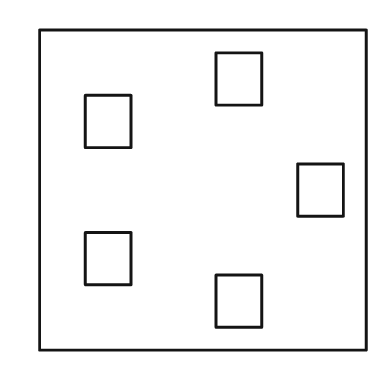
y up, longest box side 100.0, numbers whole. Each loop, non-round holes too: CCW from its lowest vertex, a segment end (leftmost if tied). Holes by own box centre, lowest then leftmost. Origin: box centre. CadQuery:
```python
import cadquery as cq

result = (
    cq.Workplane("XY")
    .moveTo(-50.0, -49.0)
    .lineTo(50.0, -49.0)
    .lineTo(50.0, 49.0)
    .lineTo(-50.0, 49.0)
    .close()
    .moveTo(4.0, -42.0)
    .lineTo(18.0, -42.0)
    .lineTo(18.0, -26.0)
    .lineTo(4.0, -26.0)
    .close()
    .moveTo(-36.0, -29.0)
    .lineTo(-22.0, -29.0)
    .lineTo(-22.0, -13.0)
    .lineTo(-36.0, -13.0)
    .close()
    .moveTo(29.0, -8.0)
    .lineTo(43.0, -8.0)
    .lineTo(43.0, 8.0)
    .lineTo(29.0, 8.0)
    .close()
    .moveTo(-36.0, 13.0)
    .lineTo(-22.0, 13.0)
    .lineTo(-22.0, 29.0)
    .lineTo(-36.0, 29.0)
    .close()
    .moveTo(4.0, 26.0)
    .lineTo(18.0, 26.0)
    .lineTo(18.0, 42.0)
    .lineTo(4.0, 42.0)
    .close()
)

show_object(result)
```